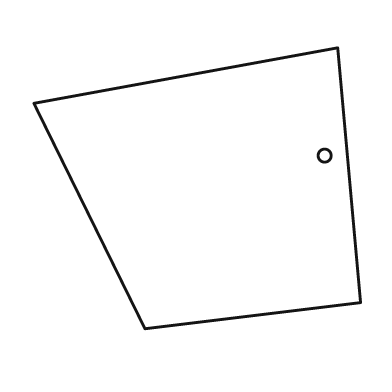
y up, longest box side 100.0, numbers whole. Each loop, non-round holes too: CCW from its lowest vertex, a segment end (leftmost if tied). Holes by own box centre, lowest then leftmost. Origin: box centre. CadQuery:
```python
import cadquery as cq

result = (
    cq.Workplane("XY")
    .moveTo(-16.0, -43.0)
    .lineTo(50.0, -35.0)
    .lineTo(43.0, 43.0)
    .lineTo(-50.0, 26.0)
    .close()
    .moveTo(39.0, 10.0)
    .circle(2.0)
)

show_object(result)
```